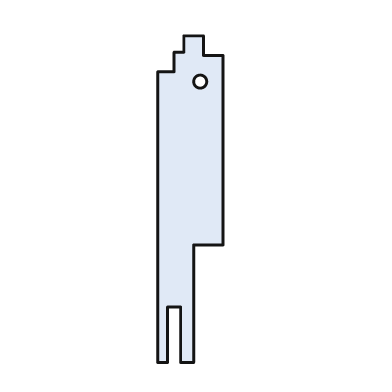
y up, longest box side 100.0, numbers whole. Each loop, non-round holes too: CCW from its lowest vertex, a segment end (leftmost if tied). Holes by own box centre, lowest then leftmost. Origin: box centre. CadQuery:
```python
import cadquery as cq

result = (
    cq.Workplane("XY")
    .moveTo(-10.0, -50.0)
    .lineTo(-7.0, -50.0)
    .lineTo(-7.0, -33.0)
    .lineTo(-3.0, -33.0)
    .lineTo(-3.0, -50.0)
    .lineTo(1.0, -50.0)
    .lineTo(1.0, -14.0)
    .lineTo(10.0, -14.0)
    .lineTo(10.0, 44.0)
    .lineTo(4.0, 44.0)
    .lineTo(4.0, 50.0)
    .lineTo(-2.0, 50.0)
    .lineTo(-2.0, 45.0)
    .lineTo(-5.0, 45.0)
    .lineTo(-5.0, 39.0)
    .lineTo(-10.0, 39.0)
    .close()
    .moveTo(3.0, 36.0)
    .circle(2.0)
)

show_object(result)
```